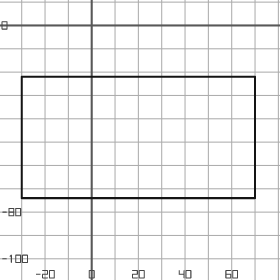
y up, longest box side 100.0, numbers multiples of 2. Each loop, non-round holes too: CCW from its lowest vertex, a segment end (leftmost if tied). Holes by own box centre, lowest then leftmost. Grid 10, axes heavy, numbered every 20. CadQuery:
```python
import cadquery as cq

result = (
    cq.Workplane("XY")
    .moveTo(-30.0, -74.0)
    .lineTo(70.0, -74.0)
    .lineTo(70.0, -22.0)
    .lineTo(-30.0, -22.0)
    .close()
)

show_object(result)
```